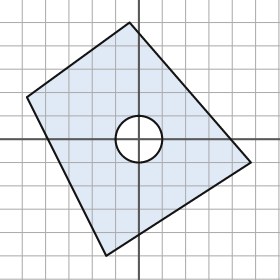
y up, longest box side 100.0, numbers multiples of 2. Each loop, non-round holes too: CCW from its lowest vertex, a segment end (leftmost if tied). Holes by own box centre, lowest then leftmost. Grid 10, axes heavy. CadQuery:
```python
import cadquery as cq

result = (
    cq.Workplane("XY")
    .moveTo(-14.0, -50.0)
    .lineTo(48.0, -10.0)
    .lineTo(-4.0, 50.0)
    .lineTo(-48.0, 18.0)
    .close()
    .moveTo(0.0, 0.0)
    .circle(10.0)
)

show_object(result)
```